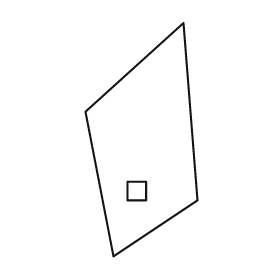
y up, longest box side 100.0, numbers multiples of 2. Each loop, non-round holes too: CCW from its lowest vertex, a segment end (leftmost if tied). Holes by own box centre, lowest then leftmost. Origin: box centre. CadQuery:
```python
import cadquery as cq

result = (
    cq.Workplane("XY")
    .moveTo(-12.0, -50.0)
    .lineTo(24.0, -26.0)
    .lineTo(18.0, 50.0)
    .lineTo(-24.0, 12.0)
    .close()
    .moveTo(-6.0, -26.0)
    .lineTo(2.0, -26.0)
    .lineTo(2.0, -18.0)
    .lineTo(-6.0, -18.0)
    .close()
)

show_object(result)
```